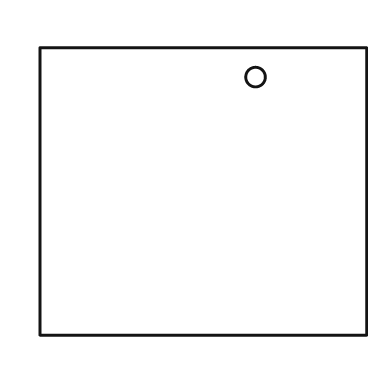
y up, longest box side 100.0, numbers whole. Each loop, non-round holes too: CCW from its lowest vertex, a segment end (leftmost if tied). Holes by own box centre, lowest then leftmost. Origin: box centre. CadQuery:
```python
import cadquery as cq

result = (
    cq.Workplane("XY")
    .moveTo(-50.0, -44.0)
    .lineTo(50.0, -44.0)
    .lineTo(50.0, 44.0)
    .lineTo(-50.0, 44.0)
    .close()
    .moveTo(16.0, 35.0)
    .circle(3.0)
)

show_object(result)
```